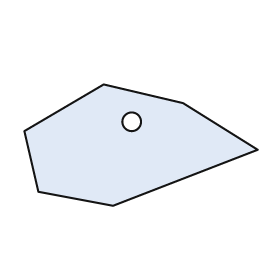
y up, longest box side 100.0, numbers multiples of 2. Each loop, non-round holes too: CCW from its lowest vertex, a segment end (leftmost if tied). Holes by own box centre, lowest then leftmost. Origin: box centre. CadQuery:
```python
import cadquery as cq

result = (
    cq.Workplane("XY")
    .moveTo(-12.0, -26.0)
    .lineTo(50.0, -2.0)
    .lineTo(18.0, 18.0)
    .lineTo(-16.0, 26.0)
    .lineTo(-50.0, 6.0)
    .lineTo(-44.0, -20.0)
    .close()
    .moveTo(-4.0, 10.0)
    .circle(4.0)
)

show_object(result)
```